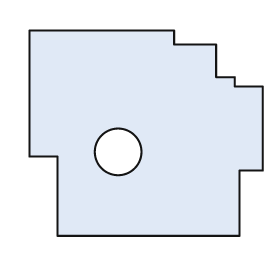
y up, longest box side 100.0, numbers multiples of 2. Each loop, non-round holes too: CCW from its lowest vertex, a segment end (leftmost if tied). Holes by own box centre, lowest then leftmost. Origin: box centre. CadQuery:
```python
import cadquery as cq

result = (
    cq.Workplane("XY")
    .moveTo(-38.0, -44.0)
    .lineTo(40.0, -44.0)
    .lineTo(40.0, -16.0)
    .lineTo(50.0, -16.0)
    .lineTo(50.0, 20.0)
    .lineTo(38.0, 20.0)
    .lineTo(38.0, 24.0)
    .lineTo(30.0, 24.0)
    .lineTo(30.0, 38.0)
    .lineTo(12.0, 38.0)
    .lineTo(12.0, 44.0)
    .lineTo(-50.0, 44.0)
    .lineTo(-50.0, -10.0)
    .lineTo(-38.0, -10.0)
    .close()
    .moveTo(-12.0, -8.0)
    .circle(10.0)
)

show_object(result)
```